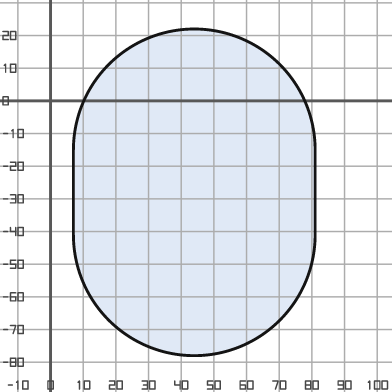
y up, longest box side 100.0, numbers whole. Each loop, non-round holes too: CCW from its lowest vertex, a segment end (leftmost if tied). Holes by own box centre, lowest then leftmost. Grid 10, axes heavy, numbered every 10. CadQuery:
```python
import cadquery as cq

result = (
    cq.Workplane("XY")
    .moveTo(7.0, -41.0)
    .threePointArc((44.0, -78.0), (81.0, -41.0))
    .lineTo(81.0, -15.0)
    .threePointArc((44.0, 22.0), (7.0, -15.0))
    .close()
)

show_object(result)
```